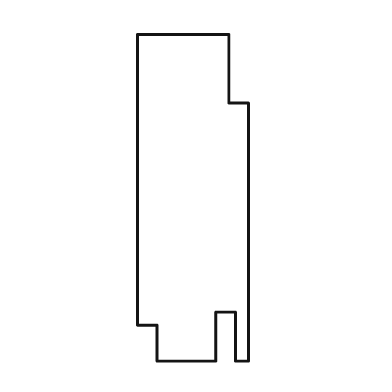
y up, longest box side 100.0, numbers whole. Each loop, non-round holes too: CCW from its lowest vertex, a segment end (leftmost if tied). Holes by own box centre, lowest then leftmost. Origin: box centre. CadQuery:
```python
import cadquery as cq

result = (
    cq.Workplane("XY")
    .moveTo(-11.0, -50.0)
    .lineTo(7.0, -50.0)
    .lineTo(7.0, -35.0)
    .lineTo(13.0, -35.0)
    .lineTo(13.0, -50.0)
    .lineTo(17.0, -50.0)
    .lineTo(17.0, 29.0)
    .lineTo(11.0, 29.0)
    .lineTo(11.0, 50.0)
    .lineTo(-17.0, 50.0)
    .lineTo(-17.0, -39.0)
    .lineTo(-11.0, -39.0)
    .close()
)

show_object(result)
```